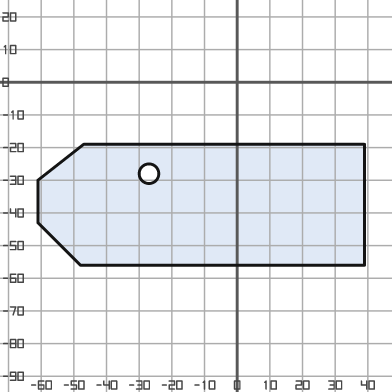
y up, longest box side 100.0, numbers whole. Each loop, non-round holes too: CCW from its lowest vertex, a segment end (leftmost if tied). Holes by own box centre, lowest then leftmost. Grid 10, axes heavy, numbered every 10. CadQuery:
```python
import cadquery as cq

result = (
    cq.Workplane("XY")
    .moveTo(-48.0, -56.0)
    .lineTo(39.0, -56.0)
    .lineTo(39.0, -19.0)
    .lineTo(-47.0, -19.0)
    .lineTo(-61.0, -30.0)
    .lineTo(-61.0, -43.0)
    .close()
    .moveTo(-27.0, -28.0)
    .circle(3.0)
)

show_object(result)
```